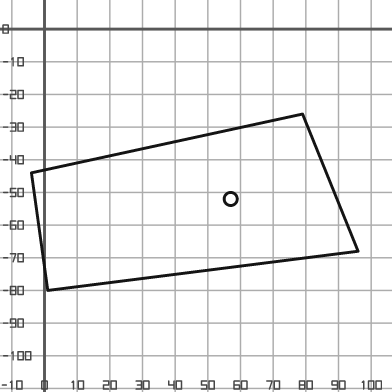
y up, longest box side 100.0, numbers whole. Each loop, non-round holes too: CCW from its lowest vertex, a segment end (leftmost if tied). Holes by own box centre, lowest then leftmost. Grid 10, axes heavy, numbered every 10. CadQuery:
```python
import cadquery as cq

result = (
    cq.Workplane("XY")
    .moveTo(1.0, -80.0)
    .lineTo(96.0, -68.0)
    .lineTo(79.0, -26.0)
    .lineTo(-4.0, -44.0)
    .close()
    .moveTo(57.0, -52.0)
    .circle(2.0)
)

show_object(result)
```